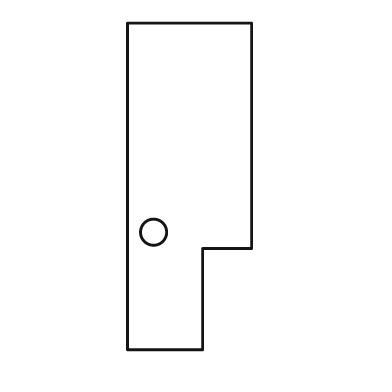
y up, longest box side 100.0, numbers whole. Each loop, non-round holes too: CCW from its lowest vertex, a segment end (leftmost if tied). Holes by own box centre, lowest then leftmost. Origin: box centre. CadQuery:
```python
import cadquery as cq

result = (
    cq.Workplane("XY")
    .moveTo(-19.0, -50.0)
    .lineTo(4.0, -50.0)
    .lineTo(4.0, -19.0)
    .lineTo(19.0, -19.0)
    .lineTo(19.0, 50.0)
    .lineTo(-19.0, 50.0)
    .close()
    .moveTo(-11.0, -14.0)
    .circle(4.0)
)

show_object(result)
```